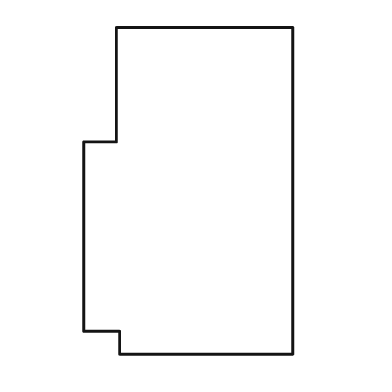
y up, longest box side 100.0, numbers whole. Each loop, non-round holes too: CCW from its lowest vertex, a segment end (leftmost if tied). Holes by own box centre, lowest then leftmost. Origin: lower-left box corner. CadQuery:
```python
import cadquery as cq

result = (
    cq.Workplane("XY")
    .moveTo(11.0, 0.0)
    .lineTo(64.0, 0.0)
    .lineTo(64.0, 100.0)
    .lineTo(10.0, 100.0)
    .lineTo(10.0, 65.0)
    .lineTo(0.0, 65.0)
    .lineTo(0.0, 7.0)
    .lineTo(11.0, 7.0)
    .close()
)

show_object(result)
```